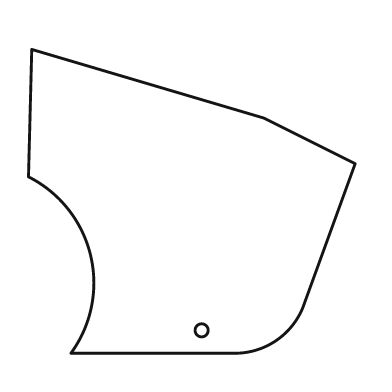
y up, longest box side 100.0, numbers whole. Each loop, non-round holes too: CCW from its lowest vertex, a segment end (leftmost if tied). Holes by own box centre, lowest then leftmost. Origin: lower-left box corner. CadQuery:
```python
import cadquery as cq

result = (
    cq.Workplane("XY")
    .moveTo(13.0, 0.0)
    .lineTo(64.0, 0.0)
    .threePointArc((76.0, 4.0), (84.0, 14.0))
    .lineTo(100.0, 58.0)
    .lineTo(72.0, 72.0)
    .lineTo(1.0, 93.0)
    .lineTo(0.0, 54.0)
    .threePointArc((19.0, 30.0), (13.0, 0.0))
    .close()
    .moveTo(53.0, 7.0)
    .circle(2.0)
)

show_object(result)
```